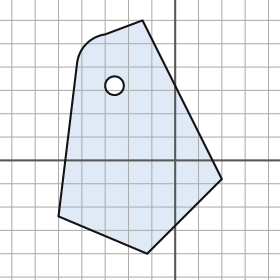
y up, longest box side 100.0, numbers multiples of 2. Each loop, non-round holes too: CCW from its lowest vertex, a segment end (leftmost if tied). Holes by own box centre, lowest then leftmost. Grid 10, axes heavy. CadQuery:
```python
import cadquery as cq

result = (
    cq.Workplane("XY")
    .moveTo(-12.0, -40.0)
    .lineTo(20.0, -8.0)
    .lineTo(-14.0, 60.0)
    .lineTo(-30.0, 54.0)
    .threePointArc((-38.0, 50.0), (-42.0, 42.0))
    .lineTo(-50.0, -24.0)
    .close()
    .moveTo(-26.0, 32.0)
    .circle(4.0)
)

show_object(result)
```